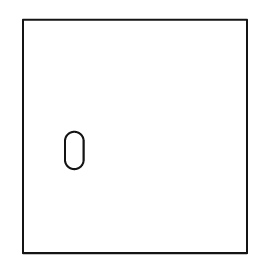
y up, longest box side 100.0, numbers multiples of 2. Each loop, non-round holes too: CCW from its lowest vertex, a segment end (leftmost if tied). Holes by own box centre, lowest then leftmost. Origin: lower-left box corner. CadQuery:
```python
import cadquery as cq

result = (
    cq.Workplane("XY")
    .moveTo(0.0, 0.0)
    .lineTo(96.0, 0.0)
    .lineTo(96.0, 100.0)
    .lineTo(0.0, 100.0)
    .close()
    .moveTo(18.0, 40.0)
    .threePointArc((22.0, 36.0), (26.0, 40.0))
    .lineTo(26.0, 48.0)
    .threePointArc((22.0, 52.0), (18.0, 48.0))
    .close()
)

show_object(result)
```